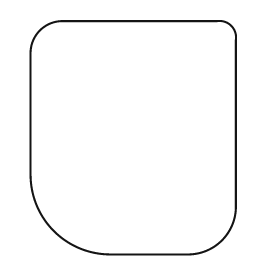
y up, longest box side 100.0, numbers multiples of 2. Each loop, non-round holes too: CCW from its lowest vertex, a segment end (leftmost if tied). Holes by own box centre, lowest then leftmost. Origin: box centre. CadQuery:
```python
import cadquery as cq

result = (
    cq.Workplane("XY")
    .moveTo(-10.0, -50.0)
    .lineTo(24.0, -50.0)
    .threePointArc((38.0, -44.0), (44.0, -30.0))
    .lineTo(44.0, 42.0)
    .threePointArc((42.0, 48.0), (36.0, 50.0))
    .lineTo(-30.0, 50.0)
    .threePointArc((-40.0, 46.0), (-44.0, 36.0))
    .lineTo(-44.0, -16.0)
    .threePointArc((-34.0, -40.0), (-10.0, -50.0))
    .close()
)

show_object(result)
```